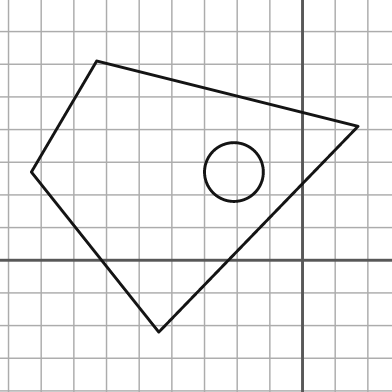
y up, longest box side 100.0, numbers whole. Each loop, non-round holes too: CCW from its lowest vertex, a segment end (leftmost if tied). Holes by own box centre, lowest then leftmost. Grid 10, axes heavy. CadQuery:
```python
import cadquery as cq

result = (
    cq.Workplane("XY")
    .moveTo(-44.0, -22.0)
    .lineTo(17.0, 41.0)
    .lineTo(-63.0, 61.0)
    .lineTo(-83.0, 27.0)
    .close()
    .moveTo(-21.0, 27.0)
    .circle(9.0)
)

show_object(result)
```